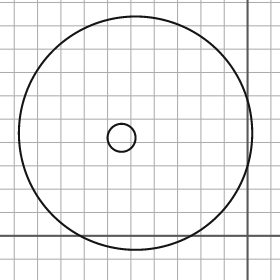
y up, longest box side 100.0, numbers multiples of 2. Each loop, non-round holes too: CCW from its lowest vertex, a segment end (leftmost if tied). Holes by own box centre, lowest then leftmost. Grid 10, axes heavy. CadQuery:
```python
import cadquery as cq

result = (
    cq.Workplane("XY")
    .moveTo(-48.0, 44.0)
    .circle(50.0)
    .moveTo(-54.0, 42.0)
    .circle(6.0)
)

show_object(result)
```